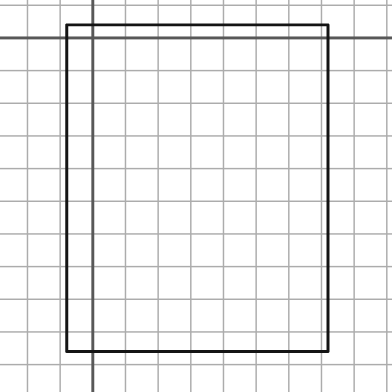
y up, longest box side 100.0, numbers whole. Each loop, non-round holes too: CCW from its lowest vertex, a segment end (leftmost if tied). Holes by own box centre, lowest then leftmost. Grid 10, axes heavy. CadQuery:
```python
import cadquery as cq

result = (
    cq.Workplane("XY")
    .moveTo(-8.0, -96.0)
    .lineTo(72.0, -96.0)
    .lineTo(72.0, 4.0)
    .lineTo(-8.0, 4.0)
    .close()
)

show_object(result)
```